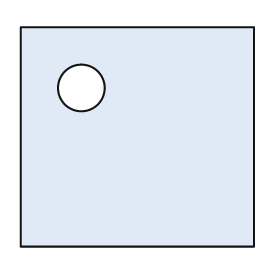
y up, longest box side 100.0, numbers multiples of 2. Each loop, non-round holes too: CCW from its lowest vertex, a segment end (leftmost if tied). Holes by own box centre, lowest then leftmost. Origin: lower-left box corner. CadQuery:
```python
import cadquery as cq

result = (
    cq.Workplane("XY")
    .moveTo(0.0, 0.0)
    .lineTo(100.0, 0.0)
    .lineTo(100.0, 94.0)
    .lineTo(0.0, 94.0)
    .close()
    .moveTo(26.0, 68.0)
    .circle(10.0)
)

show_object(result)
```